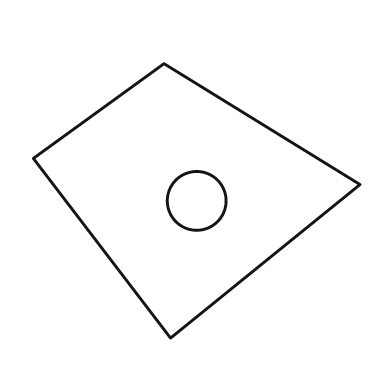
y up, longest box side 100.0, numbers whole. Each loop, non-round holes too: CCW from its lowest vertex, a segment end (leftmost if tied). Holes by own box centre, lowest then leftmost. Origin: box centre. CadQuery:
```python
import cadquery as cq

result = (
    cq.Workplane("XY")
    .moveTo(-8.0, -42.0)
    .lineTo(50.0, 5.0)
    .lineTo(-10.0, 42.0)
    .lineTo(-50.0, 13.0)
    .close()
    .moveTo(0.0, 0.0)
    .circle(9.0)
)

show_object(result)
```